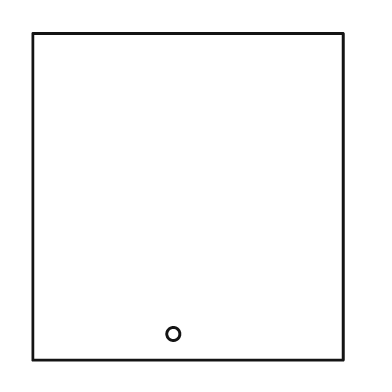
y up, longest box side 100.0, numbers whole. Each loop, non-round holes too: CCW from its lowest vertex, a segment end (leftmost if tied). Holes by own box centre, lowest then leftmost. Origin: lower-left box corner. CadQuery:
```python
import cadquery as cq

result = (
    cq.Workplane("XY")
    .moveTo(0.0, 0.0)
    .lineTo(95.0, 0.0)
    .lineTo(95.0, 100.0)
    .lineTo(0.0, 100.0)
    .close()
    .moveTo(43.0, 8.0)
    .circle(2.0)
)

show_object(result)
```